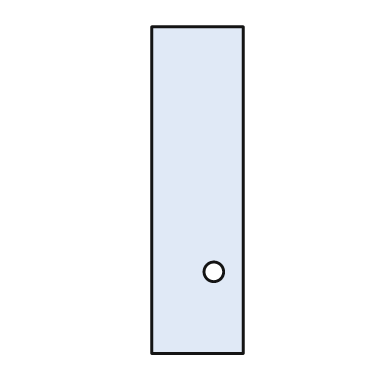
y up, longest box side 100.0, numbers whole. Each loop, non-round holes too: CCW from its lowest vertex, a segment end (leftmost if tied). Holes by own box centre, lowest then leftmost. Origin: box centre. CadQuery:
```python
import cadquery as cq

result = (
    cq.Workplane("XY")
    .moveTo(-14.0, -50.0)
    .lineTo(14.0, -50.0)
    .lineTo(14.0, 50.0)
    .lineTo(-14.0, 50.0)
    .close()
    .moveTo(5.0, -25.0)
    .circle(3.0)
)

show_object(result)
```